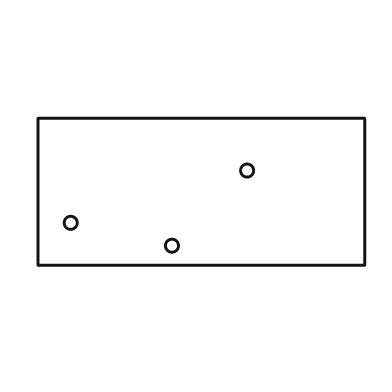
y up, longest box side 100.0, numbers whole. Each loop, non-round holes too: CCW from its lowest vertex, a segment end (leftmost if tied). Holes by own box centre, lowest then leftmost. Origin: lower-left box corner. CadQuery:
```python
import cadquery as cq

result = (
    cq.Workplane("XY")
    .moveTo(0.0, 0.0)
    .lineTo(100.0, 0.0)
    .lineTo(100.0, 45.0)
    .lineTo(0.0, 45.0)
    .close()
    .moveTo(41.0, 6.0)
    .circle(2.0)
    .moveTo(10.0, 13.0)
    .circle(2.0)
    .moveTo(64.0, 29.0)
    .circle(2.0)
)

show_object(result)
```